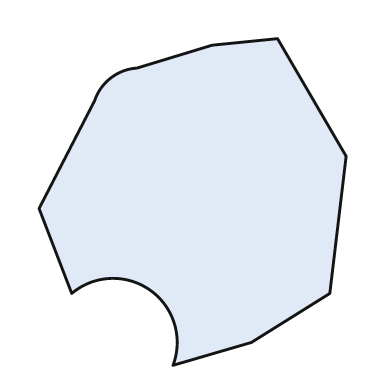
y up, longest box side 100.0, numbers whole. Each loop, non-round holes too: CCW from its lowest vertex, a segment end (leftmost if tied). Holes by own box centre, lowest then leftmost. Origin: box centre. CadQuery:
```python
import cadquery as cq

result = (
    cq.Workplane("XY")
    .moveTo(-6.0, -50.0)
    .lineTo(18.0, -43.0)
    .lineTo(42.0, -28.0)
    .lineTo(47.0, 14.0)
    .lineTo(26.0, 50.0)
    .lineTo(6.0, 48.0)
    .lineTo(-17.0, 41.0)
    .threePointArc((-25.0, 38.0), (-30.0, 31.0))
    .lineTo(-47.0, -2.0)
    .lineTo(-37.0, -28.0)
    .threePointArc((-13.0, -27.0), (-6.0, -50.0))
    .close()
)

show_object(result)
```